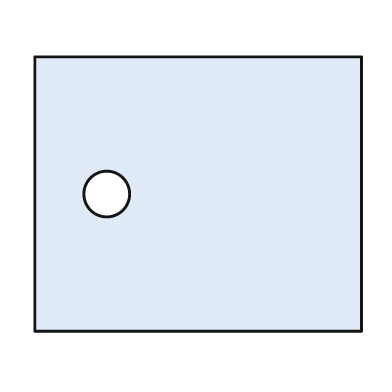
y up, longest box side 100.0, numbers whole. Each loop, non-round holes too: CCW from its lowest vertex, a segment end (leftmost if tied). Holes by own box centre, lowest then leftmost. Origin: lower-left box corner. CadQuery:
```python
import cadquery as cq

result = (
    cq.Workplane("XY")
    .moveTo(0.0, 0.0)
    .lineTo(100.0, 0.0)
    .lineTo(100.0, 84.0)
    .lineTo(0.0, 84.0)
    .close()
    .moveTo(22.0, 42.0)
    .circle(7.0)
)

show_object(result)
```